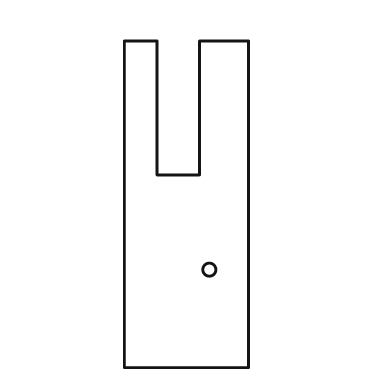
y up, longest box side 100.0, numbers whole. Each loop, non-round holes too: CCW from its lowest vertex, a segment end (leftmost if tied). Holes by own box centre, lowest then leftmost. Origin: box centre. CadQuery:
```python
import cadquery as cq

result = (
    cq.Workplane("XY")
    .moveTo(-19.0, -50.0)
    .lineTo(19.0, -50.0)
    .lineTo(19.0, 50.0)
    .lineTo(4.0, 50.0)
    .lineTo(4.0, 9.0)
    .lineTo(-9.0, 9.0)
    .lineTo(-9.0, 50.0)
    .lineTo(-19.0, 50.0)
    .close()
    .moveTo(7.0, -20.0)
    .circle(2.0)
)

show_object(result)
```